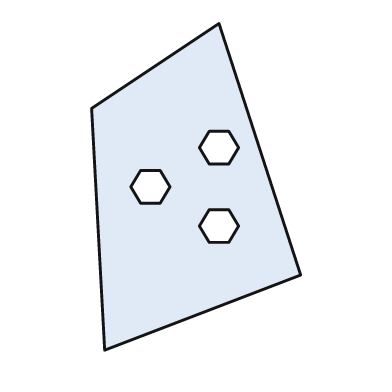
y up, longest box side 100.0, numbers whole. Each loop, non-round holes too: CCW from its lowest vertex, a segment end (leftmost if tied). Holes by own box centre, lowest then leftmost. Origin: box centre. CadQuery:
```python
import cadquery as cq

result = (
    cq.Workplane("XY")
    .moveTo(-28.0, -50.0)
    .lineTo(32.0, -27.0)
    .lineTo(7.0, 50.0)
    .lineTo(-32.0, 24.0)
    .close()
    .moveTo(4.0, -17.0)
    .lineTo(10.0, -17.0)
    .lineTo(13.0, -12.0)
    .lineTo(10.0, -7.0)
    .lineTo(4.0, -7.0)
    .lineTo(1.0, -12.0)
    .close()
    .moveTo(-17.0, -5.0)
    .lineTo(-11.0, -5.0)
    .lineTo(-8.0, 0.0)
    .lineTo(-11.0, 5.0)
    .lineTo(-17.0, 5.0)
    .lineTo(-20.0, 0.0)
    .close()
    .moveTo(4.0, 7.0)
    .lineTo(10.0, 7.0)
    .lineTo(13.0, 12.0)
    .lineTo(10.0, 17.0)
    .lineTo(4.0, 17.0)
    .lineTo(1.0, 12.0)
    .close()
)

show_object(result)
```